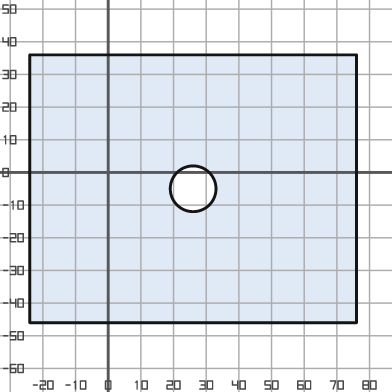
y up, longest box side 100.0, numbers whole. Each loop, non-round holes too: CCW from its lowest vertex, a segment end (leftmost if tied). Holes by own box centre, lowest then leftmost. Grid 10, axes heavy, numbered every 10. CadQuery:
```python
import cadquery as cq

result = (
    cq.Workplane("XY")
    .moveTo(-24.0, -46.0)
    .lineTo(76.0, -46.0)
    .lineTo(76.0, 36.0)
    .lineTo(-24.0, 36.0)
    .close()
    .moveTo(26.0, -5.0)
    .circle(7.0)
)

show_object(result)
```